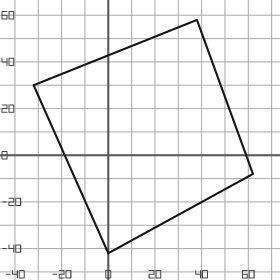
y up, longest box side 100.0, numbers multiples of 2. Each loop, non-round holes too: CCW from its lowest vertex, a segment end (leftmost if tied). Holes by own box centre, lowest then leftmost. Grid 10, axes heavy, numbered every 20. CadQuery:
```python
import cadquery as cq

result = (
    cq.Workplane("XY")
    .moveTo(0.0, -42.0)
    .lineTo(62.0, -8.0)
    .lineTo(38.0, 58.0)
    .lineTo(-32.0, 30.0)
    .close()
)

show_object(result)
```